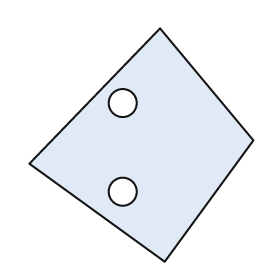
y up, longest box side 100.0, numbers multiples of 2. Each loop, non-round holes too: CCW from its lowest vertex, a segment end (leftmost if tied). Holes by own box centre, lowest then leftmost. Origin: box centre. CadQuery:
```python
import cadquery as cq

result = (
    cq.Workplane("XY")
    .moveTo(10.0, -50.0)
    .lineTo(48.0, 2.0)
    .lineTo(8.0, 50.0)
    .lineTo(-48.0, -8.0)
    .close()
    .moveTo(-8.0, -20.0)
    .circle(6.0)
    .moveTo(-8.0, 18.0)
    .circle(6.0)
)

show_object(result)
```